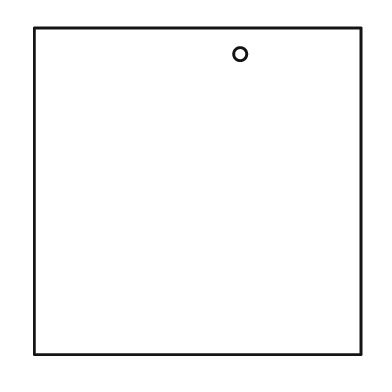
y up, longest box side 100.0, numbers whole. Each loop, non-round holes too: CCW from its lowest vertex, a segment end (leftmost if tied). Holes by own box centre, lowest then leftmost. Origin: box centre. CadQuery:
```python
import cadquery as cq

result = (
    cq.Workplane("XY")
    .moveTo(-50.0, -50.0)
    .lineTo(50.0, -50.0)
    .lineTo(50.0, 50.0)
    .lineTo(-50.0, 50.0)
    .close()
    .moveTo(13.0, 42.0)
    .circle(2.0)
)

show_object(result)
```